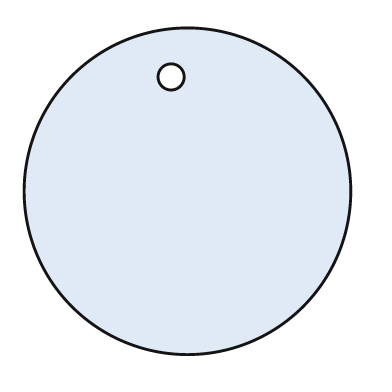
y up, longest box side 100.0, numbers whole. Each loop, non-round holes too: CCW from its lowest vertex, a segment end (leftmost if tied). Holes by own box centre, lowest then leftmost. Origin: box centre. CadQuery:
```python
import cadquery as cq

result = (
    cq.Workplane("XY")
    .moveTo(0.0, 0.0)
    .circle(50.0)
    .moveTo(-5.0, 35.0)
    .circle(4.0)
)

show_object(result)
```